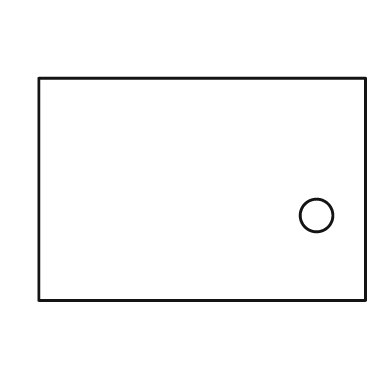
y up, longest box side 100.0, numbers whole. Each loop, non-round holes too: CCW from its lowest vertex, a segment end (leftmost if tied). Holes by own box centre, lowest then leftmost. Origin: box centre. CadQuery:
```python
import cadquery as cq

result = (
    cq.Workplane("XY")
    .moveTo(-50.0, -34.0)
    .lineTo(50.0, -34.0)
    .lineTo(50.0, 34.0)
    .lineTo(-50.0, 34.0)
    .close()
    .moveTo(35.0, -8.0)
    .circle(5.0)
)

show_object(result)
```